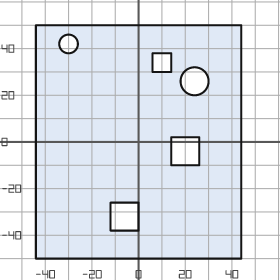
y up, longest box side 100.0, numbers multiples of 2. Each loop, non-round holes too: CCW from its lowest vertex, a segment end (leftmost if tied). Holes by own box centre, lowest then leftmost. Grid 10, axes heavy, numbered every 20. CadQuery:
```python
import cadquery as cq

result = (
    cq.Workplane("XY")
    .moveTo(-44.0, -50.0)
    .lineTo(44.0, -50.0)
    .lineTo(44.0, 50.0)
    .lineTo(-44.0, 50.0)
    .close()
    .moveTo(-12.0, -38.0)
    .lineTo(0.0, -38.0)
    .lineTo(0.0, -26.0)
    .lineTo(-12.0, -26.0)
    .close()
    .moveTo(14.0, -10.0)
    .lineTo(26.0, -10.0)
    .lineTo(26.0, 2.0)
    .lineTo(14.0, 2.0)
    .close()
    .moveTo(24.0, 26.0)
    .circle(6.0)
    .moveTo(6.0, 30.0)
    .lineTo(14.0, 30.0)
    .lineTo(14.0, 38.0)
    .lineTo(6.0, 38.0)
    .close()
    .moveTo(-30.0, 42.0)
    .circle(4.0)
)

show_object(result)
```